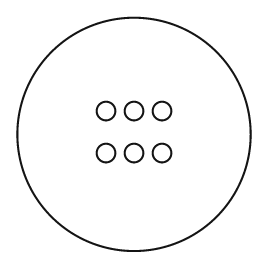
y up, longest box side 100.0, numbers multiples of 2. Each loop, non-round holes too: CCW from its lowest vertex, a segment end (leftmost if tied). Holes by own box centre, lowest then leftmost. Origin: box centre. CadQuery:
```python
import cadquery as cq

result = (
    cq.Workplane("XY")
    .moveTo(0.0, 0.0)
    .circle(50.0)
    .moveTo(-12.0, -8.0)
    .circle(4.0)
    .moveTo(0.0, -8.0)
    .circle(4.0)
    .moveTo(12.0, -8.0)
    .circle(4.0)
    .moveTo(-12.0, 10.0)
    .circle(4.0)
    .moveTo(0.0, 10.0)
    .circle(4.0)
    .moveTo(12.0, 10.0)
    .circle(4.0)
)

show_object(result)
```